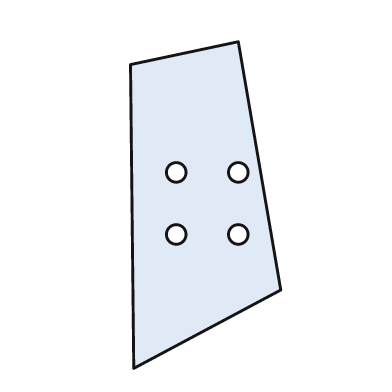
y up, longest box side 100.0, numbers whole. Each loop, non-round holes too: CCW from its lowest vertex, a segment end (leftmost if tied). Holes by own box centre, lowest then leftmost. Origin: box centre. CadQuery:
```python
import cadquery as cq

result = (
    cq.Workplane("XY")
    .moveTo(-22.0, -50.0)
    .lineTo(23.0, -26.0)
    .lineTo(10.0, 50.0)
    .lineTo(-23.0, 43.0)
    .close()
    .moveTo(-9.0, -9.0)
    .circle(3.0)
    .moveTo(10.0, -9.0)
    .circle(3.0)
    .moveTo(-9.0, 10.0)
    .circle(3.0)
    .moveTo(10.0, 10.0)
    .circle(3.0)
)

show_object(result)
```